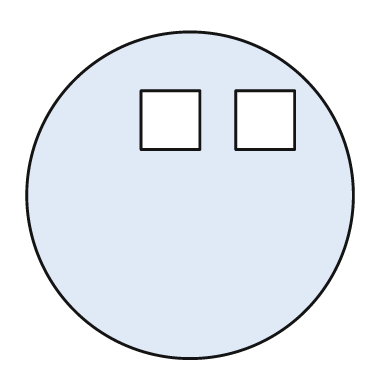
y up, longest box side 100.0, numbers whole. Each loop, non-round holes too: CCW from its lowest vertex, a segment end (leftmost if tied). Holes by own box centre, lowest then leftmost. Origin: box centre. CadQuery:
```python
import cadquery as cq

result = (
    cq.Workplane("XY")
    .moveTo(0.0, 0.0)
    .circle(50.0)
    .moveTo(-15.0, 14.0)
    .lineTo(3.0, 14.0)
    .lineTo(3.0, 32.0)
    .lineTo(-15.0, 32.0)
    .close()
    .moveTo(14.0, 14.0)
    .lineTo(32.0, 14.0)
    .lineTo(32.0, 32.0)
    .lineTo(14.0, 32.0)
    .close()
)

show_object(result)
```